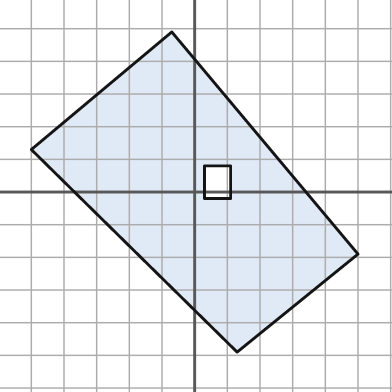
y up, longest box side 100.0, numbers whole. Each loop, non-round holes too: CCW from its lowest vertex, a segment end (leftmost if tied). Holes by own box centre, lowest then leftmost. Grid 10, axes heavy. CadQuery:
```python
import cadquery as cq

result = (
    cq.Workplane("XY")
    .moveTo(13.0, -49.0)
    .lineTo(50.0, -19.0)
    .lineTo(-7.0, 49.0)
    .lineTo(-50.0, 13.0)
    .close()
    .moveTo(3.0, -2.0)
    .lineTo(11.0, -2.0)
    .lineTo(11.0, 8.0)
    .lineTo(3.0, 8.0)
    .close()
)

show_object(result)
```